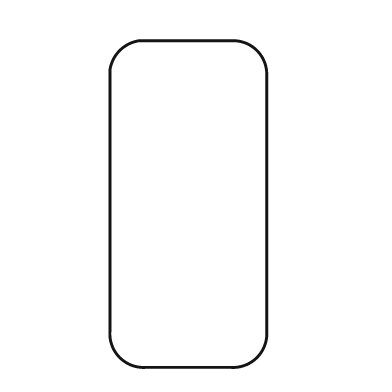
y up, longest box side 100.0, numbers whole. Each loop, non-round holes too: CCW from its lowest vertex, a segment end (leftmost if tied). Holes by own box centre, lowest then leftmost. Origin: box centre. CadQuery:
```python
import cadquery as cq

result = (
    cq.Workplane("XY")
    .moveTo(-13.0, -50.0)
    .lineTo(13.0, -50.0)
    .threePointArc((21.0, -47.0), (24.0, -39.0))
    .lineTo(24.0, 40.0)
    .threePointArc((21.0, 47.0), (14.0, 50.0))
    .lineTo(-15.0, 50.0)
    .threePointArc((-21.0, 47.0), (-24.0, 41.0))
    .lineTo(-24.0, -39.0)
    .threePointArc((-21.0, -47.0), (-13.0, -50.0))
    .close()
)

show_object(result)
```